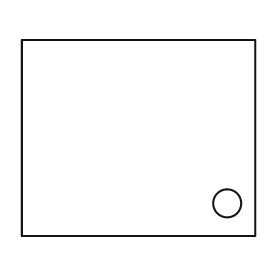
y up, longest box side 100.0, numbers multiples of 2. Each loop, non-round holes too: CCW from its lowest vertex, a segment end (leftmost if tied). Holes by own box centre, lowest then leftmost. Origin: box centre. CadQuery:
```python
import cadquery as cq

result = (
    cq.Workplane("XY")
    .moveTo(-50.0, -42.0)
    .lineTo(50.0, -42.0)
    .lineTo(50.0, 42.0)
    .lineTo(-50.0, 42.0)
    .close()
    .moveTo(38.0, -28.0)
    .circle(6.0)
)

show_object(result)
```